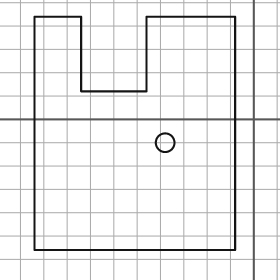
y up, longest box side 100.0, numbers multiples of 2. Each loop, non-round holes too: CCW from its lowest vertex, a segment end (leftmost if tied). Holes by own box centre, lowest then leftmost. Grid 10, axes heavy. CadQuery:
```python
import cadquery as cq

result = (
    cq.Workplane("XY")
    .moveTo(-94.0, -56.0)
    .lineTo(-8.0, -56.0)
    .lineTo(-8.0, 44.0)
    .lineTo(-46.0, 44.0)
    .lineTo(-46.0, 12.0)
    .lineTo(-74.0, 12.0)
    .lineTo(-74.0, 44.0)
    .lineTo(-94.0, 44.0)
    .close()
    .moveTo(-38.0, -10.0)
    .circle(4.0)
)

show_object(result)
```